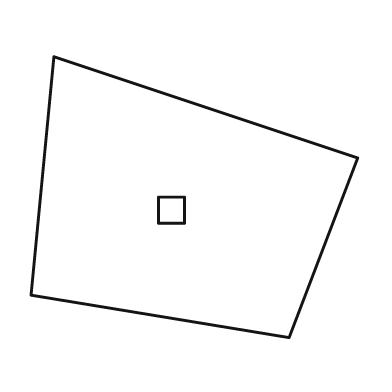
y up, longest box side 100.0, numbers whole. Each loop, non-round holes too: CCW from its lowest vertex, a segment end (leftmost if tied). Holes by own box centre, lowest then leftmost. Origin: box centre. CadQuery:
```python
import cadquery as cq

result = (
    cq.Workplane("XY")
    .moveTo(29.0, -43.0)
    .lineTo(50.0, 12.0)
    .lineTo(-43.0, 43.0)
    .lineTo(-50.0, -30.0)
    .close()
    .moveTo(-11.0, -8.0)
    .lineTo(-3.0, -8.0)
    .lineTo(-3.0, 0.0)
    .lineTo(-11.0, 0.0)
    .close()
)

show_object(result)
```